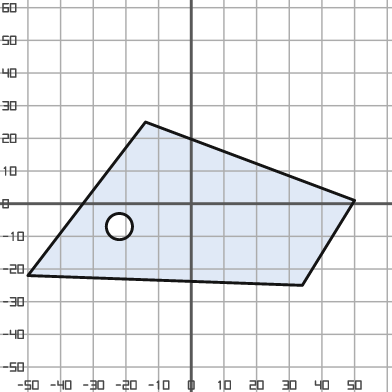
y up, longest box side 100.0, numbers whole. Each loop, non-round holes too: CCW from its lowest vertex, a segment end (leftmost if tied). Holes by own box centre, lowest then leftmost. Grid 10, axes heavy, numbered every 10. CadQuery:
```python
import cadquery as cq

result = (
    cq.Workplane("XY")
    .moveTo(34.0, -25.0)
    .lineTo(50.0, 1.0)
    .lineTo(-14.0, 25.0)
    .lineTo(-50.0, -22.0)
    .close()
    .moveTo(-22.0, -7.0)
    .circle(4.0)
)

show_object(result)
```